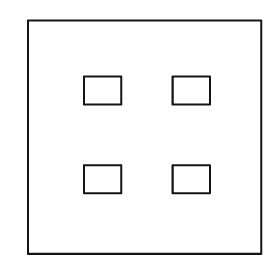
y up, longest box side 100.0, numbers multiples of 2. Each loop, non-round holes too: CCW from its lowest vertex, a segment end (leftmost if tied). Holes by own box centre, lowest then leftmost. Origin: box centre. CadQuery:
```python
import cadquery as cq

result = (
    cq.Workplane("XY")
    .moveTo(-50.0, -50.0)
    .lineTo(50.0, -50.0)
    .lineTo(50.0, 50.0)
    .lineTo(-50.0, 50.0)
    .close()
    .moveTo(-26.0, -24.0)
    .lineTo(-10.0, -24.0)
    .lineTo(-10.0, -12.0)
    .lineTo(-26.0, -12.0)
    .close()
    .moveTo(12.0, -24.0)
    .lineTo(28.0, -24.0)
    .lineTo(28.0, -12.0)
    .lineTo(12.0, -12.0)
    .close()
    .moveTo(-26.0, 14.0)
    .lineTo(-10.0, 14.0)
    .lineTo(-10.0, 26.0)
    .lineTo(-26.0, 26.0)
    .close()
    .moveTo(12.0, 14.0)
    .lineTo(28.0, 14.0)
    .lineTo(28.0, 26.0)
    .lineTo(12.0, 26.0)
    .close()
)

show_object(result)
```